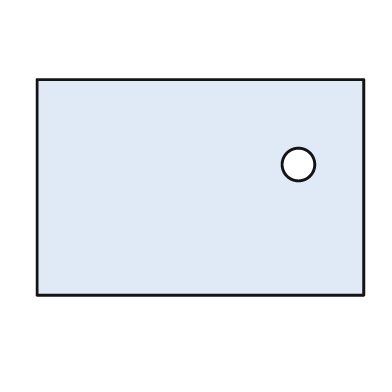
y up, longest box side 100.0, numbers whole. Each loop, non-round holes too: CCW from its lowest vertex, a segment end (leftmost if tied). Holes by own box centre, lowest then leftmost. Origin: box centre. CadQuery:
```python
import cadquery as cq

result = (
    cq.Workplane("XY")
    .moveTo(-50.0, -33.0)
    .lineTo(50.0, -33.0)
    .lineTo(50.0, 33.0)
    .lineTo(-50.0, 33.0)
    .close()
    .moveTo(30.0, 7.0)
    .circle(5.0)
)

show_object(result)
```